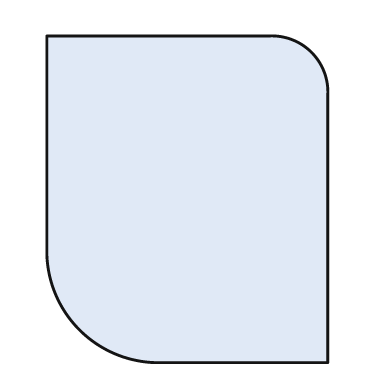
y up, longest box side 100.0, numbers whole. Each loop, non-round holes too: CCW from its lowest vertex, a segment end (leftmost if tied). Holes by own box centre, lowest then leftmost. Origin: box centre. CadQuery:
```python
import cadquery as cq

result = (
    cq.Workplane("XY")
    .moveTo(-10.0, -50.0)
    .lineTo(43.0, -50.0)
    .lineTo(43.0, 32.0)
    .threePointArc((38.0, 45.0), (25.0, 50.0))
    .lineTo(-43.0, 50.0)
    .lineTo(-43.0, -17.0)
    .threePointArc((-33.0, -40.0), (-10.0, -50.0))
    .close()
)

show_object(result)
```